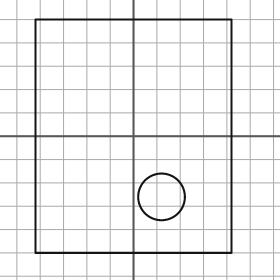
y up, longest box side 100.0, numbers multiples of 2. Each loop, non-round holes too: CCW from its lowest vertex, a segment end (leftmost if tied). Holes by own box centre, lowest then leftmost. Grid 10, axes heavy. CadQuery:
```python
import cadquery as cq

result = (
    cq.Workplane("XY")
    .moveTo(-42.0, -50.0)
    .lineTo(42.0, -50.0)
    .lineTo(42.0, 50.0)
    .lineTo(-42.0, 50.0)
    .close()
    .moveTo(12.0, -26.0)
    .circle(10.0)
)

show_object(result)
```